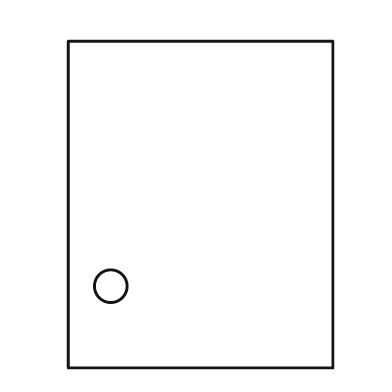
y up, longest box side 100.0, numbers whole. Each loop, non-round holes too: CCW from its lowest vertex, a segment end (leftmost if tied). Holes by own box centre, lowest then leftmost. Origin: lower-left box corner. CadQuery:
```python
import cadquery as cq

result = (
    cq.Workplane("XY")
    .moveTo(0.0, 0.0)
    .lineTo(81.0, 0.0)
    .lineTo(81.0, 100.0)
    .lineTo(0.0, 100.0)
    .close()
    .moveTo(13.0, 25.0)
    .circle(5.0)
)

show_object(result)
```